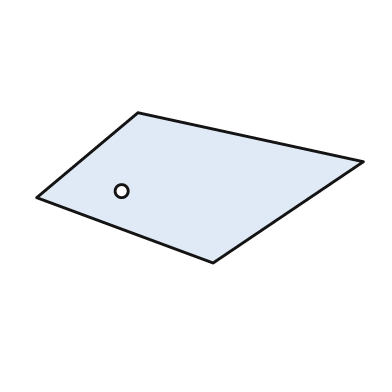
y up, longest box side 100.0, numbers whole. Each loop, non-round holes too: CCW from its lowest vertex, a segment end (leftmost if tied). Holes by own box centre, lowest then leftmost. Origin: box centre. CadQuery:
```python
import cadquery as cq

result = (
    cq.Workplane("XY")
    .moveTo(4.0, -23.0)
    .lineTo(50.0, 8.0)
    .lineTo(-19.0, 23.0)
    .lineTo(-50.0, -3.0)
    .close()
    .moveTo(-24.0, -1.0)
    .circle(2.0)
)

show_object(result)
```